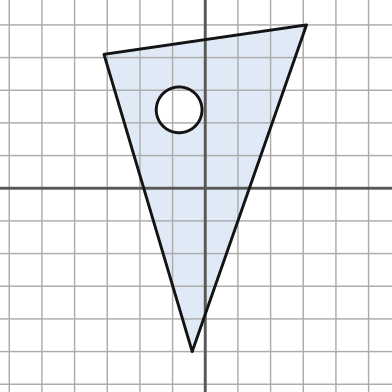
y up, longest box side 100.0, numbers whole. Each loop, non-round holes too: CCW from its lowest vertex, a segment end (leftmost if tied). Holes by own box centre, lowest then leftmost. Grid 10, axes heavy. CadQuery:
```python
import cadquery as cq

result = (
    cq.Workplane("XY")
    .moveTo(-4.0, -50.0)
    .lineTo(31.0, 50.0)
    .lineTo(-31.0, 41.0)
    .close()
    .moveTo(-8.0, 24.0)
    .circle(7.0)
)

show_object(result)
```